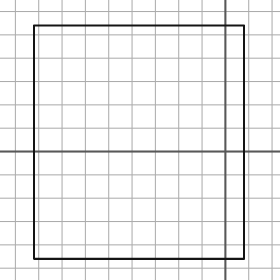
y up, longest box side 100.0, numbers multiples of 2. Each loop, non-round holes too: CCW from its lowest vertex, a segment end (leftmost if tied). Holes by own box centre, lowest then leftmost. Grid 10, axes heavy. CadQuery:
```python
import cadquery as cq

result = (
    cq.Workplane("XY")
    .moveTo(-82.0, -46.0)
    .lineTo(8.0, -46.0)
    .lineTo(8.0, 54.0)
    .lineTo(-82.0, 54.0)
    .close()
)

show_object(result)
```